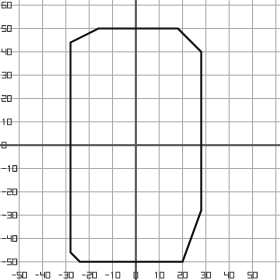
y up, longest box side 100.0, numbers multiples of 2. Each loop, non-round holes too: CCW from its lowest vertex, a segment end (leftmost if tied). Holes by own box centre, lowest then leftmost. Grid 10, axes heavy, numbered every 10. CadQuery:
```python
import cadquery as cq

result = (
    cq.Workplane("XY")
    .moveTo(-24.0, -50.0)
    .lineTo(20.0, -50.0)
    .lineTo(28.0, -28.0)
    .lineTo(28.0, 40.0)
    .lineTo(18.0, 50.0)
    .lineTo(-16.0, 50.0)
    .lineTo(-28.0, 44.0)
    .lineTo(-28.0, -46.0)
    .close()
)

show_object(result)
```